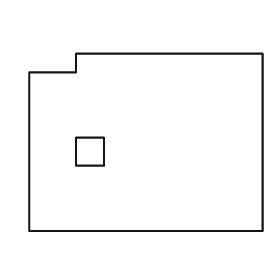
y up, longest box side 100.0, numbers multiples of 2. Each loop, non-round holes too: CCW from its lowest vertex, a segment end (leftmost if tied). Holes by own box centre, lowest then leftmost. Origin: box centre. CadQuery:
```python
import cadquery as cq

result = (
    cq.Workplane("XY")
    .moveTo(-50.0, -38.0)
    .lineTo(50.0, -38.0)
    .lineTo(50.0, 38.0)
    .lineTo(-30.0, 38.0)
    .lineTo(-30.0, 30.0)
    .lineTo(-50.0, 30.0)
    .close()
    .moveTo(-30.0, -10.0)
    .lineTo(-18.0, -10.0)
    .lineTo(-18.0, 2.0)
    .lineTo(-30.0, 2.0)
    .close()
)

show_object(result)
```